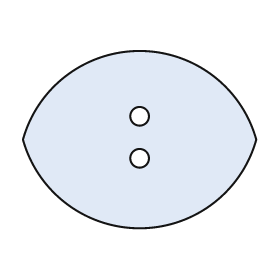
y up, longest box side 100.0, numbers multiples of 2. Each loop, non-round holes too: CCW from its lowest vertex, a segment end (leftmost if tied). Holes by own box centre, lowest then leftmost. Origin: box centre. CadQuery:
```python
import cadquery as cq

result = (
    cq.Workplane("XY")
    .moveTo(-50.0, 0.0)
    .threePointArc((0.0, -38.0), (50.0, 0.0))
    .threePointArc((0.0, 38.0), (-50.0, 0.0))
    .close()
    .moveTo(0.0, -8.0)
    .circle(4.0)
    .moveTo(0.0, 10.0)
    .circle(4.0)
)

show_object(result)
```